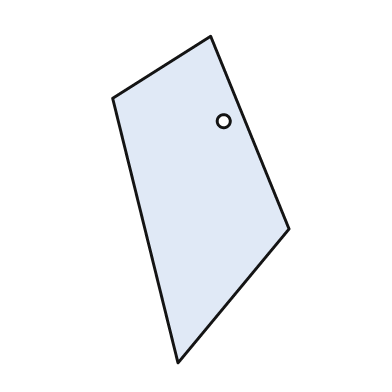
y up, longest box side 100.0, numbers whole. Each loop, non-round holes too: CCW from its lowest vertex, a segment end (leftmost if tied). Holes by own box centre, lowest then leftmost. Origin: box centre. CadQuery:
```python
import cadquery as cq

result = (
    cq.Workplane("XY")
    .moveTo(-7.0, -50.0)
    .lineTo(27.0, -9.0)
    .lineTo(3.0, 50.0)
    .lineTo(-27.0, 31.0)
    .close()
    .moveTo(7.0, 24.0)
    .circle(2.0)
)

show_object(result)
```